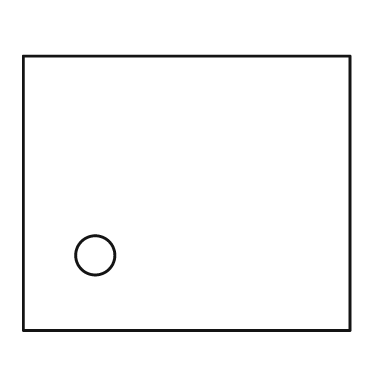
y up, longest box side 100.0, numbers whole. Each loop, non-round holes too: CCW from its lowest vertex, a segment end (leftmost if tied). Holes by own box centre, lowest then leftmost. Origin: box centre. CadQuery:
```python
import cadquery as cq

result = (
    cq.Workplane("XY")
    .moveTo(-50.0, -42.0)
    .lineTo(50.0, -42.0)
    .lineTo(50.0, 42.0)
    .lineTo(-50.0, 42.0)
    .close()
    .moveTo(-28.0, -19.0)
    .circle(6.0)
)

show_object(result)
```